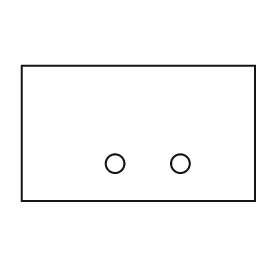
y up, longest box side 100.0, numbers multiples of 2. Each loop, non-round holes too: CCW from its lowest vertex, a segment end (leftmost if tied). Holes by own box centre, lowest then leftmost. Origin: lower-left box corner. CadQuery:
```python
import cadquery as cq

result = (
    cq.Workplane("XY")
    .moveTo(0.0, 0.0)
    .lineTo(100.0, 0.0)
    .lineTo(100.0, 58.0)
    .lineTo(0.0, 58.0)
    .close()
    .moveTo(40.0, 16.0)
    .circle(4.0)
    .moveTo(68.0, 16.0)
    .circle(4.0)
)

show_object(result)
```